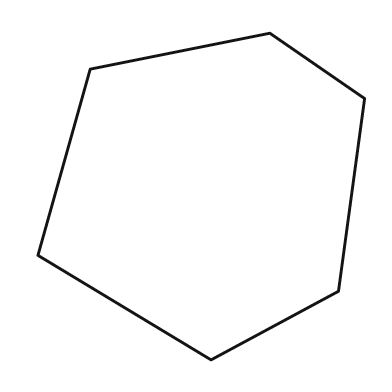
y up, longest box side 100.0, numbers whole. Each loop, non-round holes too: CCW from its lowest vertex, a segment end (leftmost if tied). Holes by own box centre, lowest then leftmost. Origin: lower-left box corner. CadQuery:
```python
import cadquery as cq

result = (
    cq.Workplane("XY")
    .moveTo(53.0, 0.0)
    .lineTo(92.0, 21.0)
    .lineTo(100.0, 80.0)
    .lineTo(71.0, 100.0)
    .lineTo(16.0, 89.0)
    .lineTo(0.0, 32.0)
    .close()
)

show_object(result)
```